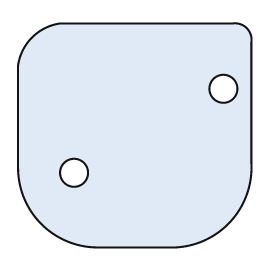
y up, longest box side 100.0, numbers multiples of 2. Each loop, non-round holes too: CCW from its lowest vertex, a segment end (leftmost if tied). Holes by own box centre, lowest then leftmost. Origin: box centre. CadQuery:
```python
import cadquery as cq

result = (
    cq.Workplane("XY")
    .moveTo(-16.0, -48.0)
    .lineTo(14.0, -48.0)
    .threePointArc((40.0, -38.0), (50.0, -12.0))
    .lineTo(50.0, 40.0)
    .threePointArc((48.0, 46.0), (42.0, 48.0))
    .lineTo(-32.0, 48.0)
    .threePointArc((-44.0, 42.0), (-50.0, 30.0))
    .lineTo(-50.0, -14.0)
    .threePointArc((-40.0, -38.0), (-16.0, -48.0))
    .close()
    .moveTo(-26.0, -16.0)
    .circle(6.0)
    .moveTo(38.0, 20.0)
    .circle(6.0)
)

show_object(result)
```